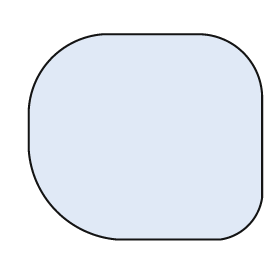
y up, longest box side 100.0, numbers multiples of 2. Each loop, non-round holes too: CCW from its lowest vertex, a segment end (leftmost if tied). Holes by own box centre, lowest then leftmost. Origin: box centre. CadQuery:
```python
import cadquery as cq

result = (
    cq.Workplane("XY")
    .moveTo(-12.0, -44.0)
    .lineTo(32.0, -44.0)
    .threePointArc((44.0, -38.0), (50.0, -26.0))
    .lineTo(50.0, 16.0)
    .threePointArc((42.0, 36.0), (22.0, 44.0))
    .lineTo(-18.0, 44.0)
    .threePointArc((-40.0, 34.0), (-50.0, 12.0))
    .lineTo(-50.0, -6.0)
    .threePointArc((-38.0, -32.0), (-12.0, -44.0))
    .close()
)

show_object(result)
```